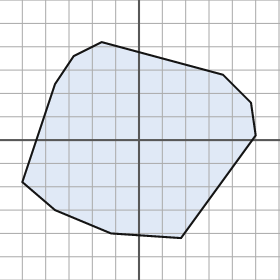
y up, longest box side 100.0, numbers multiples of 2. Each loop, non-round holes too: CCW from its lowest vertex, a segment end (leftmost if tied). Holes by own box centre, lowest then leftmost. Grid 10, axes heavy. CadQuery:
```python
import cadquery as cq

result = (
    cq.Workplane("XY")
    .moveTo(18.0, -42.0)
    .lineTo(50.0, 2.0)
    .lineTo(48.0, 16.0)
    .lineTo(36.0, 28.0)
    .lineTo(-16.0, 42.0)
    .lineTo(-28.0, 36.0)
    .lineTo(-36.0, 24.0)
    .lineTo(-50.0, -18.0)
    .lineTo(-36.0, -30.0)
    .lineTo(-12.0, -40.0)
    .close()
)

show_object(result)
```